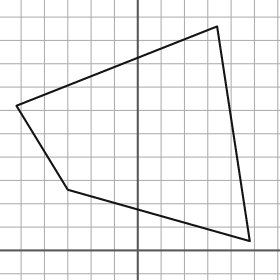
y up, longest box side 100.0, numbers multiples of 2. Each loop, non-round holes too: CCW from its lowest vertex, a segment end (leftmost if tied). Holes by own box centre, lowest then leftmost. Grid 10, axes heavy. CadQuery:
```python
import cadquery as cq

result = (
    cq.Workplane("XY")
    .moveTo(48.0, 4.0)
    .lineTo(34.0, 96.0)
    .lineTo(-52.0, 62.0)
    .lineTo(-30.0, 26.0)
    .close()
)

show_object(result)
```